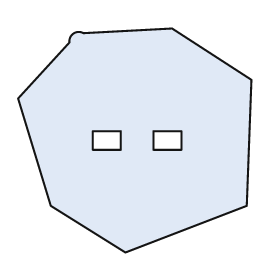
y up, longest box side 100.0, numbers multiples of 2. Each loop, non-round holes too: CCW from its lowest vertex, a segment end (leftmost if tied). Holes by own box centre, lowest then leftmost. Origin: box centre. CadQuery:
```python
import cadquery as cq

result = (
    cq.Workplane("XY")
    .moveTo(-4.0, -48.0)
    .lineTo(48.0, -28.0)
    .lineTo(50.0, 26.0)
    .lineTo(16.0, 48.0)
    .lineTo(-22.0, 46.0)
    .threePointArc((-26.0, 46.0), (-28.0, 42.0))
    .lineTo(-50.0, 18.0)
    .lineTo(-36.0, -28.0)
    .close()
    .moveTo(-18.0, -4.0)
    .lineTo(-6.0, -4.0)
    .lineTo(-6.0, 4.0)
    .lineTo(-18.0, 4.0)
    .close()
    .moveTo(8.0, -4.0)
    .lineTo(20.0, -4.0)
    .lineTo(20.0, 4.0)
    .lineTo(8.0, 4.0)
    .close()
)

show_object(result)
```